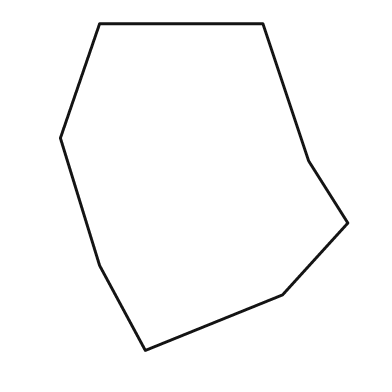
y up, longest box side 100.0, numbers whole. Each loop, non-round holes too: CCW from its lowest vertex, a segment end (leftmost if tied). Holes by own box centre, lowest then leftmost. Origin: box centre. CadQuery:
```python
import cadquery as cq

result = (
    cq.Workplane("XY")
    .moveTo(-18.0, -50.0)
    .lineTo(24.0, -33.0)
    .lineTo(44.0, -11.0)
    .lineTo(32.0, 8.0)
    .lineTo(18.0, 50.0)
    .lineTo(-32.0, 50.0)
    .lineTo(-44.0, 15.0)
    .lineTo(-32.0, -24.0)
    .close()
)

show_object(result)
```